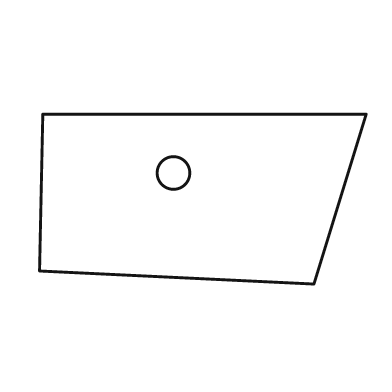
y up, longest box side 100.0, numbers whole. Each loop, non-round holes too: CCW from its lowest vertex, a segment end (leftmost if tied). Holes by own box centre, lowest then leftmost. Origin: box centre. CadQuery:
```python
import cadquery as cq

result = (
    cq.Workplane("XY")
    .moveTo(34.0, -26.0)
    .lineTo(50.0, 26.0)
    .lineTo(-49.0, 26.0)
    .lineTo(-50.0, -22.0)
    .close()
    .moveTo(-9.0, 8.0)
    .circle(5.0)
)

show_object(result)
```